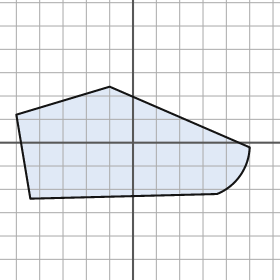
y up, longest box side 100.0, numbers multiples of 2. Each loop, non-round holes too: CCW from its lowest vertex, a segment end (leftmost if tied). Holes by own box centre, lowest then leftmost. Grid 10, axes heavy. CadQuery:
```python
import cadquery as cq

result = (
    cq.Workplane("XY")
    .moveTo(-44.0, -24.0)
    .lineTo(36.0, -22.0)
    .threePointArc((46.0, -14.0), (50.0, -2.0))
    .lineTo(-10.0, 24.0)
    .lineTo(-50.0, 12.0)
    .close()
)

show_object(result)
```